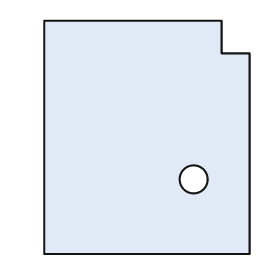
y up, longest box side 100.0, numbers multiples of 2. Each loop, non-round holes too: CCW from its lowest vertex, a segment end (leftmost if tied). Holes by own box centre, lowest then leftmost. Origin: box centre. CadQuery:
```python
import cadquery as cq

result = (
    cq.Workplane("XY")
    .moveTo(-44.0, -50.0)
    .lineTo(44.0, -50.0)
    .lineTo(44.0, 36.0)
    .lineTo(32.0, 36.0)
    .lineTo(32.0, 50.0)
    .lineTo(-44.0, 50.0)
    .close()
    .moveTo(20.0, -18.0)
    .circle(6.0)
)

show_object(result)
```